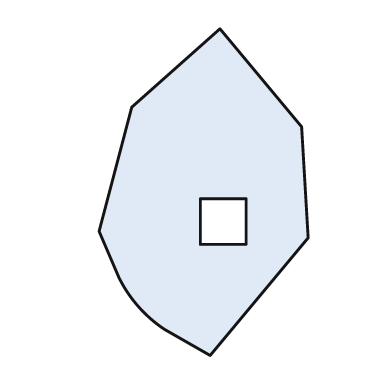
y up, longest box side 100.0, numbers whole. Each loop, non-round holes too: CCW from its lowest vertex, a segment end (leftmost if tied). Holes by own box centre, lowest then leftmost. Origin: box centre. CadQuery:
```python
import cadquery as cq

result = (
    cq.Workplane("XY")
    .moveTo(2.0, -50.0)
    .lineTo(32.0, -14.0)
    .lineTo(30.0, 20.0)
    .lineTo(5.0, 50.0)
    .lineTo(-22.0, 26.0)
    .lineTo(-32.0, -12.0)
    .lineTo(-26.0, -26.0)
    .threePointArc((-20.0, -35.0), (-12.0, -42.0))
    .close()
    .moveTo(-1.0, -16.0)
    .lineTo(13.0, -16.0)
    .lineTo(13.0, -2.0)
    .lineTo(-1.0, -2.0)
    .close()
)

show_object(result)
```